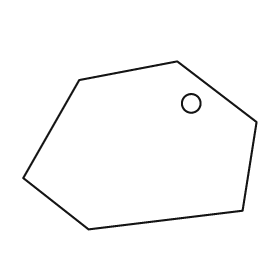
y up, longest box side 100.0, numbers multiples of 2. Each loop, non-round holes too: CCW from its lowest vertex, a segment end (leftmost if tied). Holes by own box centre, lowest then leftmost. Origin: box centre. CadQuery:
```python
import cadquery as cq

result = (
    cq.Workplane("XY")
    .moveTo(-22.0, -36.0)
    .lineTo(44.0, -28.0)
    .lineTo(50.0, 10.0)
    .lineTo(16.0, 36.0)
    .lineTo(-26.0, 28.0)
    .lineTo(-50.0, -14.0)
    .close()
    .moveTo(22.0, 18.0)
    .circle(4.0)
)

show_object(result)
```